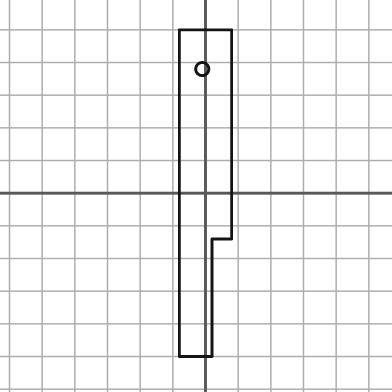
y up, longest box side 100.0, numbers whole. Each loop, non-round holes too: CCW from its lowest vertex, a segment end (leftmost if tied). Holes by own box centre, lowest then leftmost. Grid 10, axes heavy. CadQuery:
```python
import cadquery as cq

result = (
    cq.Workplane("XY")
    .moveTo(-8.0, -50.0)
    .lineTo(2.0, -50.0)
    .lineTo(2.0, -14.0)
    .lineTo(8.0, -14.0)
    .lineTo(8.0, 50.0)
    .lineTo(-8.0, 50.0)
    .close()
    .moveTo(-1.0, 38.0)
    .circle(2.0)
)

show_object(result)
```